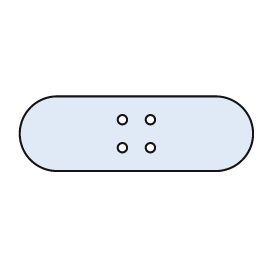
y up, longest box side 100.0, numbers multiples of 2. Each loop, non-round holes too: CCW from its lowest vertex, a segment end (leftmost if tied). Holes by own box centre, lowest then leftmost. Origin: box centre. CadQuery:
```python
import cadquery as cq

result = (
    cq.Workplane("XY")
    .moveTo(-34.0, -16.0)
    .lineTo(34.0, -16.0)
    .threePointArc((50.0, 0.0), (34.0, 16.0))
    .lineTo(-34.0, 16.0)
    .threePointArc((-50.0, 0.0), (-34.0, -16.0))
    .close()
    .moveTo(-6.0, -6.0)
    .circle(2.0)
    .moveTo(6.0, -6.0)
    .circle(2.0)
    .moveTo(-6.0, 6.0)
    .circle(2.0)
    .moveTo(6.0, 6.0)
    .circle(2.0)
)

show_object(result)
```